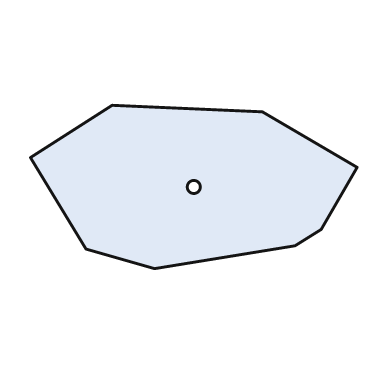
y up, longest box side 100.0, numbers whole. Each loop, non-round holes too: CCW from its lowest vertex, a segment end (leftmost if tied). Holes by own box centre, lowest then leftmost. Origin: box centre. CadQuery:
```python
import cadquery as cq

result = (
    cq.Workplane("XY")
    .moveTo(-12.0, -25.0)
    .lineTo(31.0, -18.0)
    .lineTo(39.0, -13.0)
    .lineTo(50.0, 6.0)
    .lineTo(21.0, 23.0)
    .lineTo(-25.0, 25.0)
    .lineTo(-50.0, 9.0)
    .lineTo(-33.0, -19.0)
    .close()
    .moveTo(0.0, 0.0)
    .circle(2.0)
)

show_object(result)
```